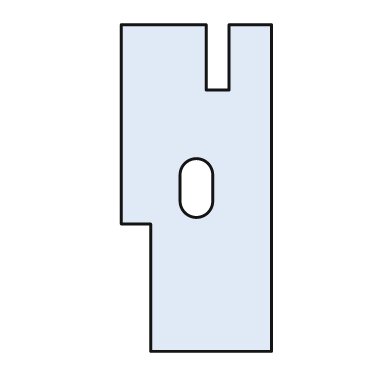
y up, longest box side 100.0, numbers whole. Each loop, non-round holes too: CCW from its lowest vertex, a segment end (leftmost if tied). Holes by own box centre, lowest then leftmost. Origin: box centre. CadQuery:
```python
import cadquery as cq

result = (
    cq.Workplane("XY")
    .moveTo(-14.0, -50.0)
    .lineTo(23.0, -50.0)
    .lineTo(23.0, 50.0)
    .lineTo(10.0, 50.0)
    .lineTo(10.0, 30.0)
    .lineTo(3.0, 30.0)
    .lineTo(3.0, 50.0)
    .lineTo(-23.0, 50.0)
    .lineTo(-23.0, -11.0)
    .lineTo(-14.0, -11.0)
    .close()
    .moveTo(-5.0, -4.0)
    .threePointArc((0.0, -9.0), (5.0, -4.0))
    .lineTo(5.0, 4.0)
    .threePointArc((0.0, 9.0), (-5.0, 4.0))
    .close()
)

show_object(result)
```